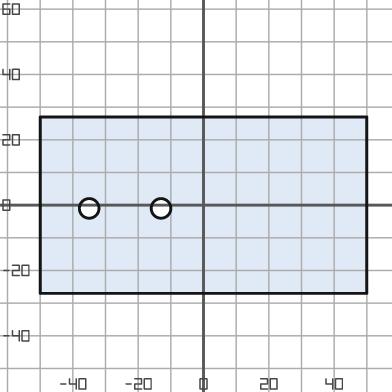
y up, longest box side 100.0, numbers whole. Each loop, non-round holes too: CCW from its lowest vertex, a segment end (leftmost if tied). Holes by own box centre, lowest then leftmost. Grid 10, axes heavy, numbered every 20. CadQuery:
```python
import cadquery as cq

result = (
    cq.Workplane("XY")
    .moveTo(-50.0, -27.0)
    .lineTo(50.0, -27.0)
    .lineTo(50.0, 27.0)
    .lineTo(-50.0, 27.0)
    .close()
    .moveTo(-35.0, -1.0)
    .circle(3.0)
    .moveTo(-13.0, -1.0)
    .circle(3.0)
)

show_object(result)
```